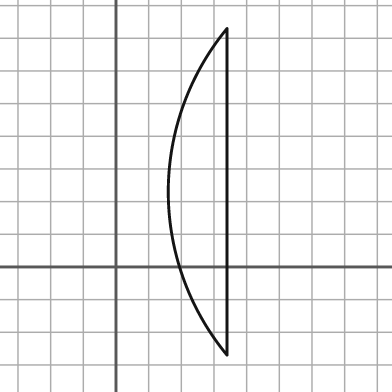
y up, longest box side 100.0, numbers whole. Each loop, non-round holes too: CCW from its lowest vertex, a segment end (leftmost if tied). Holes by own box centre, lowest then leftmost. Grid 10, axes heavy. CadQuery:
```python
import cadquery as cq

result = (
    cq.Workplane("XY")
    .moveTo(34.0, -27.0)
    .lineTo(34.0, 73.0)
    .threePointArc((16.0, 23.0), (34.0, -27.0))
    .close()
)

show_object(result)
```